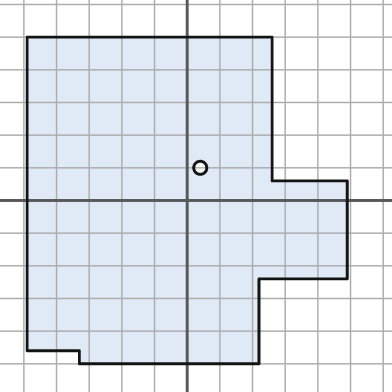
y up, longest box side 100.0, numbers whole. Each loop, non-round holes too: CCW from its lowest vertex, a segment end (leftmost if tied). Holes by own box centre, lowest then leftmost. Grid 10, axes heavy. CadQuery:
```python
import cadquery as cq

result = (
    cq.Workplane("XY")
    .moveTo(-33.0, -50.0)
    .lineTo(22.0, -50.0)
    .lineTo(22.0, -24.0)
    .lineTo(49.0, -24.0)
    .lineTo(49.0, 6.0)
    .lineTo(26.0, 6.0)
    .lineTo(26.0, 50.0)
    .lineTo(-49.0, 50.0)
    .lineTo(-49.0, -46.0)
    .lineTo(-33.0, -46.0)
    .close()
    .moveTo(4.0, 10.0)
    .circle(2.0)
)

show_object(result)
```